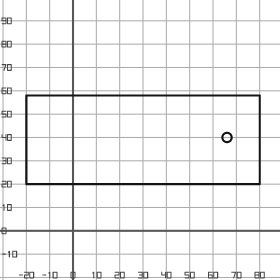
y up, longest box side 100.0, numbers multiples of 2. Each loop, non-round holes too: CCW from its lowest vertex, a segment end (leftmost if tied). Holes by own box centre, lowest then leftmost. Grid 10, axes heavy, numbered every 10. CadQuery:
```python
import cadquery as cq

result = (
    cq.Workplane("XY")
    .moveTo(-20.0, 20.0)
    .lineTo(80.0, 20.0)
    .lineTo(80.0, 58.0)
    .lineTo(-20.0, 58.0)
    .close()
    .moveTo(66.0, 40.0)
    .circle(2.0)
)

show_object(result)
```